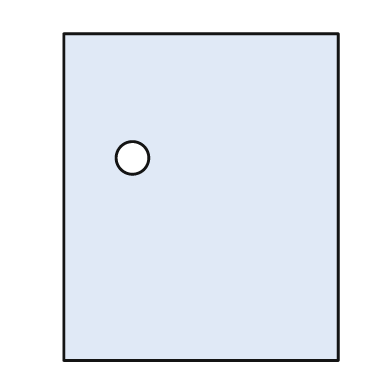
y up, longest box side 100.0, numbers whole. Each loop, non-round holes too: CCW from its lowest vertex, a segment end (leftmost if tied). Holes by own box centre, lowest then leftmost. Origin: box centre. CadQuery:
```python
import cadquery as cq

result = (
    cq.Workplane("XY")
    .moveTo(-42.0, -50.0)
    .lineTo(42.0, -50.0)
    .lineTo(42.0, 50.0)
    .lineTo(-42.0, 50.0)
    .close()
    .moveTo(-21.0, 12.0)
    .circle(5.0)
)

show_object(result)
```